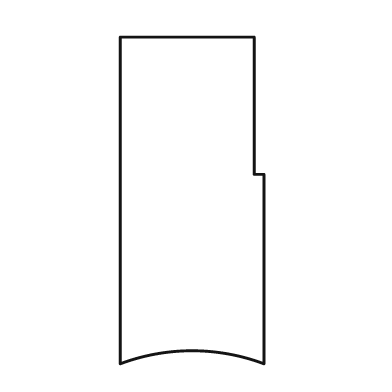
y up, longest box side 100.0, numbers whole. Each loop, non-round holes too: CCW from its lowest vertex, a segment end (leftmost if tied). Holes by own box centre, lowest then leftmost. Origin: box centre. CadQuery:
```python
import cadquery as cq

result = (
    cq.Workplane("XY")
    .moveTo(-22.0, -50.0)
    .threePointArc((0.0, -46.0), (22.0, -50.0))
    .lineTo(22.0, 8.0)
    .lineTo(19.0, 8.0)
    .lineTo(19.0, 50.0)
    .lineTo(-22.0, 50.0)
    .close()
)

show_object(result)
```